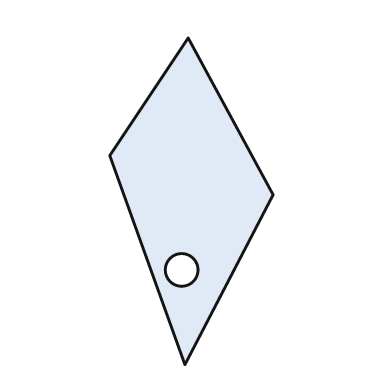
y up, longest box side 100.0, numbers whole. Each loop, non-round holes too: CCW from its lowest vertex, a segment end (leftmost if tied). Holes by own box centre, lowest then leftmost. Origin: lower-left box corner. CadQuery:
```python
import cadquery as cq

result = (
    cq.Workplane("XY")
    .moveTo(23.0, 0.0)
    .lineTo(50.0, 52.0)
    .lineTo(24.0, 100.0)
    .lineTo(0.0, 64.0)
    .close()
    .moveTo(22.0, 29.0)
    .circle(5.0)
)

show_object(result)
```